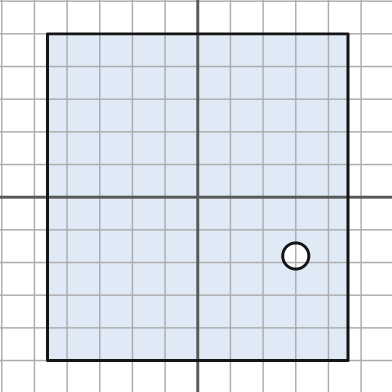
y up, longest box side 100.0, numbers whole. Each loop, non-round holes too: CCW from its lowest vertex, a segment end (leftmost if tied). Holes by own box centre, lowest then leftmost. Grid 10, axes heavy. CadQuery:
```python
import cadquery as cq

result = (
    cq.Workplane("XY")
    .moveTo(-46.0, -50.0)
    .lineTo(46.0, -50.0)
    .lineTo(46.0, 50.0)
    .lineTo(-46.0, 50.0)
    .close()
    .moveTo(30.0, -18.0)
    .circle(4.0)
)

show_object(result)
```